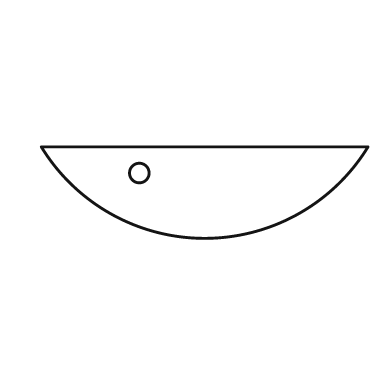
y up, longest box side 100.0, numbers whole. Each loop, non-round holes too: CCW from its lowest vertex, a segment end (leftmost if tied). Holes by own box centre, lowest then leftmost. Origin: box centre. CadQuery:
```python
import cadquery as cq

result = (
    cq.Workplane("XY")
    .moveTo(-50.0, 14.0)
    .threePointArc((0.0, -14.0), (50.0, 14.0))
    .close()
    .moveTo(-20.0, 6.0)
    .circle(3.0)
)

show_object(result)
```